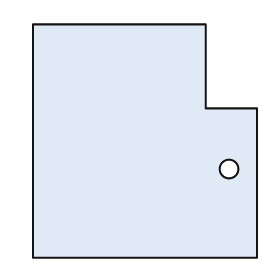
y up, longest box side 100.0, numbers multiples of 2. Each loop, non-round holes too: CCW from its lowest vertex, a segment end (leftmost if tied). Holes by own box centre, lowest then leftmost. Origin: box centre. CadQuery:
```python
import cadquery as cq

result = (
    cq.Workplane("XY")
    .moveTo(-48.0, -50.0)
    .lineTo(48.0, -50.0)
    .lineTo(48.0, 14.0)
    .lineTo(26.0, 14.0)
    .lineTo(26.0, 50.0)
    .lineTo(-48.0, 50.0)
    .close()
    .moveTo(36.0, -12.0)
    .circle(4.0)
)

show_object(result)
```